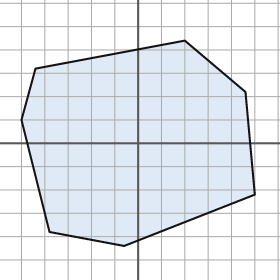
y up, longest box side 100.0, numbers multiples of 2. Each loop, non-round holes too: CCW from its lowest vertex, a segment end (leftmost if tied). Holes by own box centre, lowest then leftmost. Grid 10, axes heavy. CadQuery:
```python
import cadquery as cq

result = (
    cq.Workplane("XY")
    .moveTo(-6.0, -44.0)
    .lineTo(50.0, -22.0)
    .lineTo(46.0, 22.0)
    .lineTo(20.0, 44.0)
    .lineTo(-44.0, 32.0)
    .lineTo(-50.0, 10.0)
    .lineTo(-38.0, -38.0)
    .close()
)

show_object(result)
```